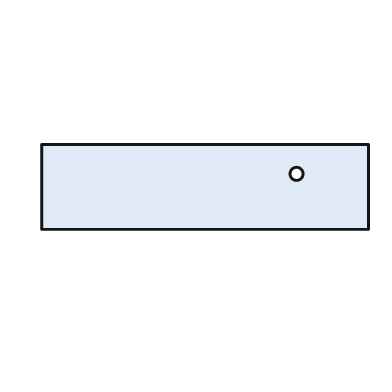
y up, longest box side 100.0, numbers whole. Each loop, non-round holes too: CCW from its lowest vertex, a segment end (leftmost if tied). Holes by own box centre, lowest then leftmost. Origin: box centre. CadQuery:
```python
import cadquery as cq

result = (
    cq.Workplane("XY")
    .moveTo(-50.0, -13.0)
    .lineTo(50.0, -13.0)
    .lineTo(50.0, 13.0)
    .lineTo(-50.0, 13.0)
    .close()
    .moveTo(28.0, 4.0)
    .circle(2.0)
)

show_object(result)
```